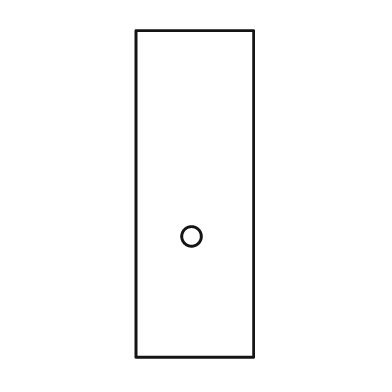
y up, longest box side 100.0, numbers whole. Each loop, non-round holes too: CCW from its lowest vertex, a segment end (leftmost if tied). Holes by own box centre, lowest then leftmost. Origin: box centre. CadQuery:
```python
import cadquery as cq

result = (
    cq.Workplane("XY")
    .moveTo(-18.0, -50.0)
    .lineTo(18.0, -50.0)
    .lineTo(18.0, 50.0)
    .lineTo(-18.0, 50.0)
    .close()
    .moveTo(-1.0, -13.0)
    .circle(3.0)
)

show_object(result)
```